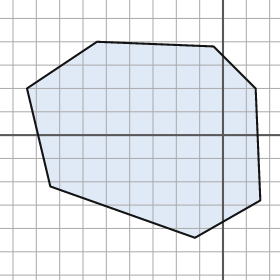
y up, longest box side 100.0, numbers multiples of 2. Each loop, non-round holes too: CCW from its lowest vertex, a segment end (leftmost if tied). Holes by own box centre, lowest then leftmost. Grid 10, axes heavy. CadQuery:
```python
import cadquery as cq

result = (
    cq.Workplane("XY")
    .moveTo(-12.0, -44.0)
    .lineTo(16.0, -28.0)
    .lineTo(14.0, 20.0)
    .lineTo(-4.0, 38.0)
    .lineTo(-54.0, 40.0)
    .lineTo(-84.0, 20.0)
    .lineTo(-74.0, -22.0)
    .close()
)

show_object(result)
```